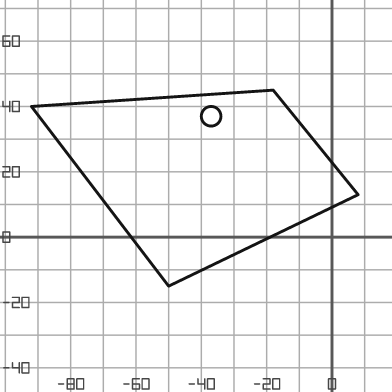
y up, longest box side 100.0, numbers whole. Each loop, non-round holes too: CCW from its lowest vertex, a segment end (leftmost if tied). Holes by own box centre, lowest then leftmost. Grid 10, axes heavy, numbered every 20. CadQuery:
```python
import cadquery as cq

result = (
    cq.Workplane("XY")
    .moveTo(-50.0, -15.0)
    .lineTo(8.0, 13.0)
    .lineTo(-18.0, 45.0)
    .lineTo(-92.0, 40.0)
    .close()
    .moveTo(-37.0, 37.0)
    .circle(3.0)
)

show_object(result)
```